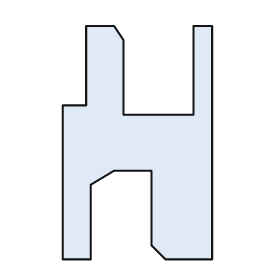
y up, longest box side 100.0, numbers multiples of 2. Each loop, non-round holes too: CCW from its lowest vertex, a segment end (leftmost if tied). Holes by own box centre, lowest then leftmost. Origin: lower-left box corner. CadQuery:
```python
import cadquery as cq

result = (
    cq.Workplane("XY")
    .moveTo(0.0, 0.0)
    .lineTo(12.0, 0.0)
    .lineTo(12.0, 32.0)
    .lineTo(22.0, 38.0)
    .lineTo(38.0, 38.0)
    .lineTo(38.0, 6.0)
    .lineTo(44.0, 0.0)
    .lineTo(64.0, 0.0)
    .lineTo(64.0, 100.0)
    .lineTo(56.0, 100.0)
    .lineTo(56.0, 62.0)
    .lineTo(26.0, 62.0)
    .lineTo(26.0, 94.0)
    .lineTo(22.0, 100.0)
    .lineTo(10.0, 100.0)
    .lineTo(10.0, 66.0)
    .lineTo(0.0, 66.0)
    .close()
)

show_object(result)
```